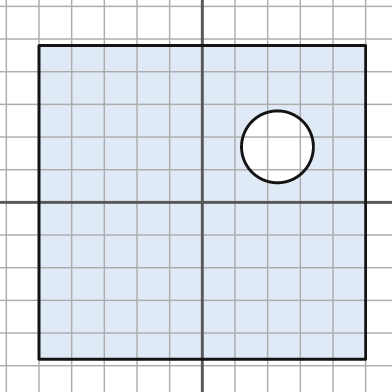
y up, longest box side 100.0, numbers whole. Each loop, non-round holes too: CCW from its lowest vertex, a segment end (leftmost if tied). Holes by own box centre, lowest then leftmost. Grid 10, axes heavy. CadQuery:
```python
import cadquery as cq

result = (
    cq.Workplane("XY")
    .moveTo(-50.0, -48.0)
    .lineTo(50.0, -48.0)
    .lineTo(50.0, 48.0)
    .lineTo(-50.0, 48.0)
    .close()
    .moveTo(23.0, 17.0)
    .circle(11.0)
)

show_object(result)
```